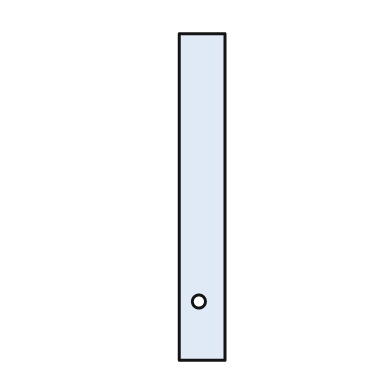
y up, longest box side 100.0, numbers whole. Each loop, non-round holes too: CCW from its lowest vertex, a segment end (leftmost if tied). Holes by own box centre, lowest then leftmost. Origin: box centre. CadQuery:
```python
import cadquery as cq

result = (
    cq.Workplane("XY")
    .moveTo(-7.0, -50.0)
    .lineTo(7.0, -50.0)
    .lineTo(7.0, 50.0)
    .lineTo(-7.0, 50.0)
    .close()
    .moveTo(-1.0, -32.0)
    .circle(2.0)
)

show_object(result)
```